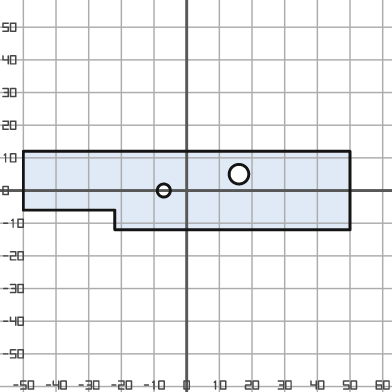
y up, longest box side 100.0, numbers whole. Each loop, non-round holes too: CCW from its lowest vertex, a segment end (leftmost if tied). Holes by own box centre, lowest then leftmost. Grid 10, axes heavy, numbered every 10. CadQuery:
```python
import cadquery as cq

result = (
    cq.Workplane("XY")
    .moveTo(-22.0, -12.0)
    .lineTo(50.0, -12.0)
    .lineTo(50.0, 12.0)
    .lineTo(-50.0, 12.0)
    .lineTo(-50.0, -6.0)
    .lineTo(-22.0, -6.0)
    .close()
    .moveTo(-7.0, 0.0)
    .circle(2.0)
    .moveTo(16.0, 5.0)
    .circle(3.0)
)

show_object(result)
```